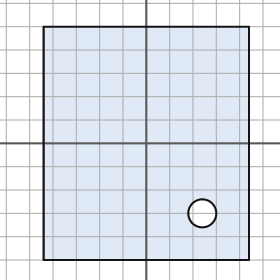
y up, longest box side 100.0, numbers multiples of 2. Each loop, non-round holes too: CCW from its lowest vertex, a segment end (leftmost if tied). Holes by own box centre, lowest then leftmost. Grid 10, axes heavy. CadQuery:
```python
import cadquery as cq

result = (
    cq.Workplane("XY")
    .moveTo(-44.0, -50.0)
    .lineTo(44.0, -50.0)
    .lineTo(44.0, 50.0)
    .lineTo(-44.0, 50.0)
    .close()
    .moveTo(24.0, -30.0)
    .circle(6.0)
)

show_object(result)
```